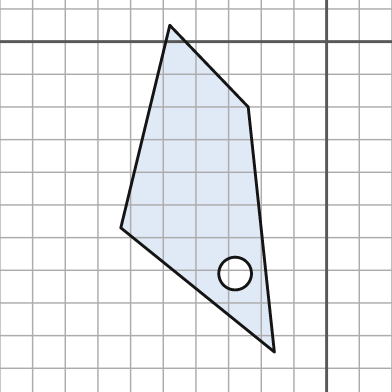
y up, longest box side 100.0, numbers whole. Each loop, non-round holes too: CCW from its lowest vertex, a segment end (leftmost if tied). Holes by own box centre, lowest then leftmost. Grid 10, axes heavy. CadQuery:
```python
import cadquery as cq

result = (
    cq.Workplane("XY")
    .moveTo(-16.0, -95.0)
    .lineTo(-24.0, -20.0)
    .lineTo(-48.0, 5.0)
    .lineTo(-63.0, -57.0)
    .close()
    .moveTo(-28.0, -71.0)
    .circle(5.0)
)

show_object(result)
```